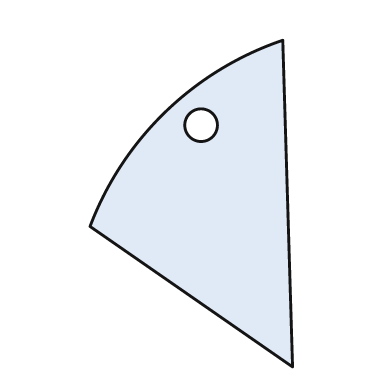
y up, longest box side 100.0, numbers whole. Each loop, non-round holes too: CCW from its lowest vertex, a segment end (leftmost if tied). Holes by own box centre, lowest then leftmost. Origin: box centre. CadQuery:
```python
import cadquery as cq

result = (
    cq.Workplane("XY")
    .moveTo(31.0, -50.0)
    .lineTo(28.0, 50.0)
    .threePointArc((-8.0, 28.0), (-31.0, -7.0))
    .close()
    .moveTo(3.0, 24.0)
    .circle(5.0)
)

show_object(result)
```